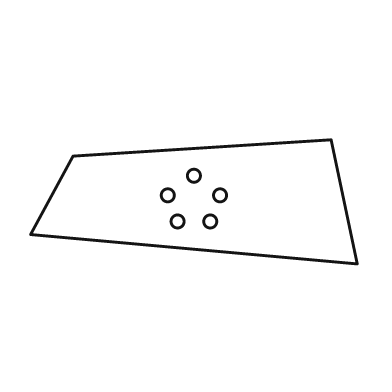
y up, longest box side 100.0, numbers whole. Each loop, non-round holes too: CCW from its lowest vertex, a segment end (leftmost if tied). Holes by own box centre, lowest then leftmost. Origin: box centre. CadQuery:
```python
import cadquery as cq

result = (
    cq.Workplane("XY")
    .moveTo(50.0, -19.0)
    .lineTo(42.0, 19.0)
    .lineTo(-37.0, 14.0)
    .lineTo(-50.0, -10.0)
    .close()
    .moveTo(-5.0, -6.0)
    .circle(2.0)
    .moveTo(5.0, -6.0)
    .circle(2.0)
    .moveTo(-8.0, 2.0)
    .circle(2.0)
    .moveTo(8.0, 2.0)
    .circle(2.0)
    .moveTo(0.0, 8.0)
    .circle(2.0)
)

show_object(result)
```